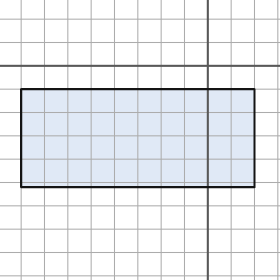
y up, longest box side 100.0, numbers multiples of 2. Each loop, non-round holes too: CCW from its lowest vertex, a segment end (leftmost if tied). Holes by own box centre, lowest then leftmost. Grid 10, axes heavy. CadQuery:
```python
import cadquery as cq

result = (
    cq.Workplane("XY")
    .moveTo(-80.0, -52.0)
    .lineTo(20.0, -52.0)
    .lineTo(20.0, -10.0)
    .lineTo(-80.0, -10.0)
    .close()
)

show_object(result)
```